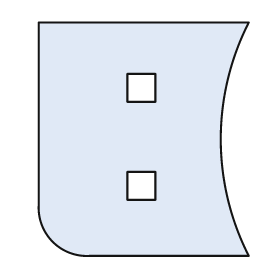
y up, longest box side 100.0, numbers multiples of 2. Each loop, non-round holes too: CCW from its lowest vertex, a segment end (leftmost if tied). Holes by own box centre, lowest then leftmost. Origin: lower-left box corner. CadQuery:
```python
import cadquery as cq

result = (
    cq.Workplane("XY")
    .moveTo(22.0, 0.0)
    .lineTo(90.0, 0.0)
    .threePointArc((78.0, 50.0), (90.0, 100.0))
    .lineTo(0.0, 100.0)
    .lineTo(0.0, 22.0)
    .threePointArc((6.0, 6.0), (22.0, 0.0))
    .close()
    .moveTo(38.0, 24.0)
    .lineTo(50.0, 24.0)
    .lineTo(50.0, 36.0)
    .lineTo(38.0, 36.0)
    .close()
    .moveTo(38.0, 66.0)
    .lineTo(50.0, 66.0)
    .lineTo(50.0, 78.0)
    .lineTo(38.0, 78.0)
    .close()
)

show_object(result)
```